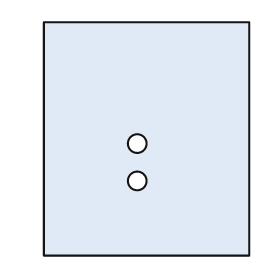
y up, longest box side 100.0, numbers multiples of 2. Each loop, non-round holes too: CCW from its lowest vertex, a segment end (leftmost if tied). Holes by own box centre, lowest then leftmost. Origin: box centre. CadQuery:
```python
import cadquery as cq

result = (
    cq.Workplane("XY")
    .moveTo(-44.0, -50.0)
    .lineTo(44.0, -50.0)
    .lineTo(44.0, 50.0)
    .lineTo(-44.0, 50.0)
    .close()
    .moveTo(-4.0, -18.0)
    .circle(4.0)
    .moveTo(-4.0, -2.0)
    .circle(4.0)
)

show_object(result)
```